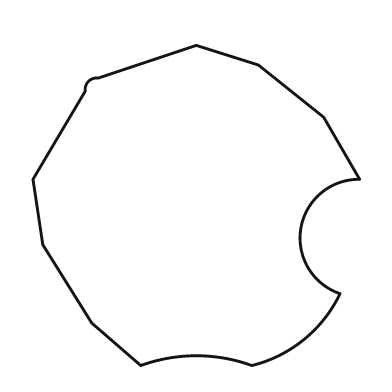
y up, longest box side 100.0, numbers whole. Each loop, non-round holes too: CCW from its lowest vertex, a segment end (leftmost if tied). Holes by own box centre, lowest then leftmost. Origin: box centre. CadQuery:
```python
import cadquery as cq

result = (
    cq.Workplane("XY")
    .moveTo(-17.0, -49.0)
    .threePointArc((0.0, -46.0), (17.0, -49.0))
    .threePointArc((33.0, -41.0), (44.0, -27.0))
    .threePointArc((32.0, -7.0), (50.0, 8.0))
    .lineTo(39.0, 27.0)
    .lineTo(19.0, 43.0)
    .lineTo(0.0, 49.0)
    .lineTo(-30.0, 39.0)
    .threePointArc((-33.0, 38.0), (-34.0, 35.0))
    .lineTo(-50.0, 8.0)
    .lineTo(-47.0, -12.0)
    .lineTo(-32.0, -36.0)
    .close()
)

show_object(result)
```